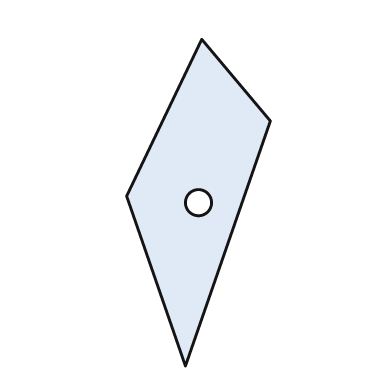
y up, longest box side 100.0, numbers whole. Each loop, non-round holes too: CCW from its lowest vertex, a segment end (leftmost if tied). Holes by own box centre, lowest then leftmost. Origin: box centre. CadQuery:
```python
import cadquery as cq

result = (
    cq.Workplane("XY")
    .moveTo(-4.0, -50.0)
    .lineTo(22.0, 25.0)
    .lineTo(1.0, 50.0)
    .lineTo(-22.0, 2.0)
    .close()
    .moveTo(0.0, 0.0)
    .circle(4.0)
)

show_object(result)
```